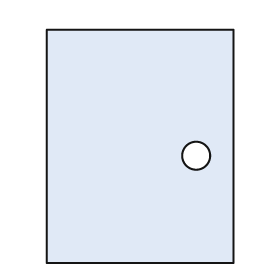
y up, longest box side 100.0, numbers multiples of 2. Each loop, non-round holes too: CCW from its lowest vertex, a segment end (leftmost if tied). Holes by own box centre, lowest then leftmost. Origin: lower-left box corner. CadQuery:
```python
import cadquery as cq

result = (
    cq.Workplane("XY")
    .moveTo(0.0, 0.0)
    .lineTo(80.0, 0.0)
    .lineTo(80.0, 100.0)
    .lineTo(0.0, 100.0)
    .close()
    .moveTo(64.0, 46.0)
    .circle(6.0)
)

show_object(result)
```